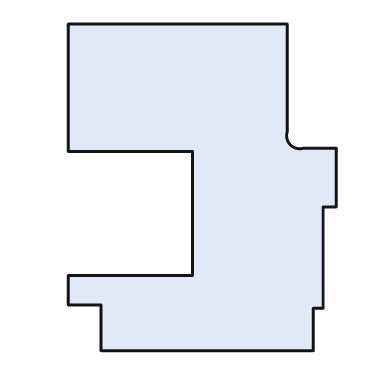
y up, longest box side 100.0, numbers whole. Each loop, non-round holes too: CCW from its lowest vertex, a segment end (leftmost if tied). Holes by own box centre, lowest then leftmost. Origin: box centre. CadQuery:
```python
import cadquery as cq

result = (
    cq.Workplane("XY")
    .moveTo(-31.0, -50.0)
    .lineTo(34.0, -50.0)
    .lineTo(34.0, -37.0)
    .lineTo(37.0, -37.0)
    .lineTo(37.0, -6.0)
    .lineTo(41.0, -6.0)
    .lineTo(41.0, 12.0)
    .lineTo(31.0, 12.0)
    .threePointArc((27.0, 13.0), (26.0, 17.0))
    .lineTo(26.0, 50.0)
    .lineTo(-41.0, 50.0)
    .lineTo(-41.0, 11.0)
    .lineTo(-3.0, 11.0)
    .lineTo(-3.0, -27.0)
    .lineTo(-41.0, -27.0)
    .lineTo(-41.0, -36.0)
    .lineTo(-31.0, -36.0)
    .close()
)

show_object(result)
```